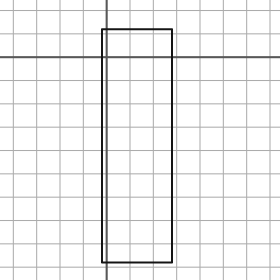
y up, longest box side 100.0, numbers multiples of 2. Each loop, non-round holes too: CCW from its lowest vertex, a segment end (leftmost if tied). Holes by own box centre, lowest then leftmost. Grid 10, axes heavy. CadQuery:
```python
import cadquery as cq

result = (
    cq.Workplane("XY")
    .moveTo(-2.0, -88.0)
    .lineTo(28.0, -88.0)
    .lineTo(28.0, 12.0)
    .lineTo(-2.0, 12.0)
    .close()
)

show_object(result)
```